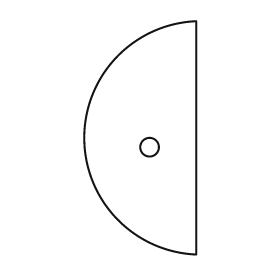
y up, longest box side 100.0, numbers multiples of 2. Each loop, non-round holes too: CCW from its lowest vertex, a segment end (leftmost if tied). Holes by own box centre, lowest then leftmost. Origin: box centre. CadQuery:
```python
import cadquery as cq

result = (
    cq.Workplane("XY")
    .moveTo(24.0, -50.0)
    .lineTo(24.0, 50.0)
    .threePointArc((-24.0, 0.0), (24.0, -50.0))
    .close()
    .moveTo(4.0, -4.0)
    .circle(4.0)
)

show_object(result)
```